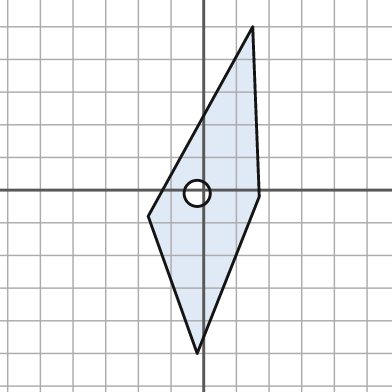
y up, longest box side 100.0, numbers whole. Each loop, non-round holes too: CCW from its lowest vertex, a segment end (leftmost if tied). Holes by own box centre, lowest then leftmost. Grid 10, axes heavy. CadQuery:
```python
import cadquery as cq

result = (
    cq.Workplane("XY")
    .moveTo(-2.0, -50.0)
    .lineTo(17.0, -2.0)
    .lineTo(15.0, 50.0)
    .lineTo(-17.0, -8.0)
    .close()
    .moveTo(-2.0, -1.0)
    .circle(4.0)
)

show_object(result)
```